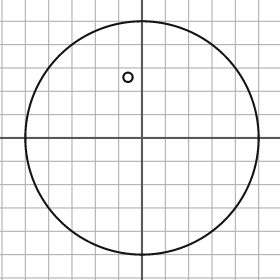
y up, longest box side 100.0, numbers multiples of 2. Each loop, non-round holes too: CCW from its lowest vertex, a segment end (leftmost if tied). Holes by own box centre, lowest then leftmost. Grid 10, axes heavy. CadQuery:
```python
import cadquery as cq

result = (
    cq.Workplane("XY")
    .moveTo(0.0, 0.0)
    .circle(50.0)
    .moveTo(-6.0, 26.0)
    .circle(2.0)
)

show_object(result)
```